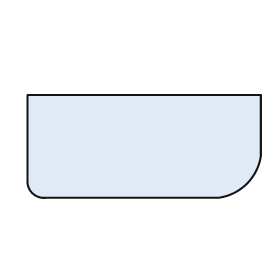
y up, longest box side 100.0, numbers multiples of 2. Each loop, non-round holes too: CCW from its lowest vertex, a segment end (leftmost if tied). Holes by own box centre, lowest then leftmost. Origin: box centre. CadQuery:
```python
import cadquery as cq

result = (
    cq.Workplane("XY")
    .moveTo(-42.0, -22.0)
    .lineTo(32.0, -22.0)
    .threePointArc((44.0, -16.0), (50.0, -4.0))
    .lineTo(50.0, 22.0)
    .lineTo(-50.0, 22.0)
    .lineTo(-50.0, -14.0)
    .threePointArc((-48.0, -20.0), (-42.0, -22.0))
    .close()
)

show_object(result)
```